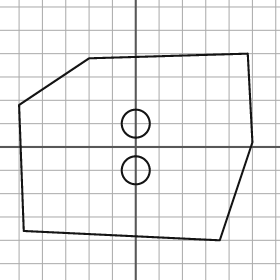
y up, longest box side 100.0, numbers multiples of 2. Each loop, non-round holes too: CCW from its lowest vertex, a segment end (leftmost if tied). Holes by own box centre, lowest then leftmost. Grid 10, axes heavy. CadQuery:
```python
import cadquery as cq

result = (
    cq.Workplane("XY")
    .moveTo(36.0, -40.0)
    .lineTo(50.0, 2.0)
    .lineTo(48.0, 40.0)
    .lineTo(-20.0, 38.0)
    .lineTo(-50.0, 18.0)
    .lineTo(-48.0, -36.0)
    .close()
    .moveTo(0.0, -10.0)
    .circle(6.0)
    .moveTo(0.0, 10.0)
    .circle(6.0)
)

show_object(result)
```